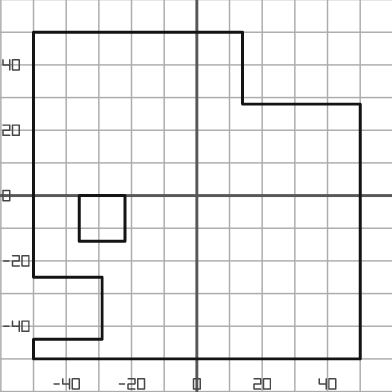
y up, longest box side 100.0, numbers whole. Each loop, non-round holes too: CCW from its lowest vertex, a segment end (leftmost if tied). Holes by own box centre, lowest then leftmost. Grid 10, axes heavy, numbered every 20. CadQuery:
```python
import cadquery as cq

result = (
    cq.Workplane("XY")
    .moveTo(-50.0, -50.0)
    .lineTo(50.0, -50.0)
    .lineTo(50.0, 28.0)
    .lineTo(14.0, 28.0)
    .lineTo(14.0, 50.0)
    .lineTo(-50.0, 50.0)
    .lineTo(-50.0, -25.0)
    .lineTo(-29.0, -25.0)
    .lineTo(-29.0, -44.0)
    .lineTo(-50.0, -44.0)
    .close()
    .moveTo(-36.0, -14.0)
    .lineTo(-22.0, -14.0)
    .lineTo(-22.0, 0.0)
    .lineTo(-36.0, 0.0)
    .close()
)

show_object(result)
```